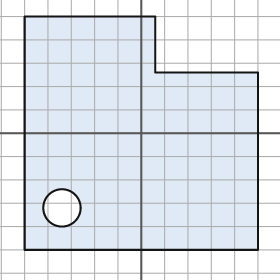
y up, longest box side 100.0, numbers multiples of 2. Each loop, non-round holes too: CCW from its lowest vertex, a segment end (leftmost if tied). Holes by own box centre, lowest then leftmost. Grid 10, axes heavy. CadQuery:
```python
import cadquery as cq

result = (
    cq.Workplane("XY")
    .moveTo(-50.0, -50.0)
    .lineTo(50.0, -50.0)
    .lineTo(50.0, 26.0)
    .lineTo(6.0, 26.0)
    .lineTo(6.0, 50.0)
    .lineTo(-50.0, 50.0)
    .close()
    .moveTo(-34.0, -32.0)
    .circle(8.0)
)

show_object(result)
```